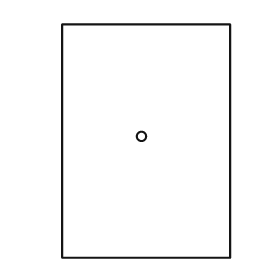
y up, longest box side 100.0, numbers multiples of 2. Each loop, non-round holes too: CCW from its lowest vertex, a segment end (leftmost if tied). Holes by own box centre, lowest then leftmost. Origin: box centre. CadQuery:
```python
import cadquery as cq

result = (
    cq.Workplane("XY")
    .moveTo(-36.0, -50.0)
    .lineTo(36.0, -50.0)
    .lineTo(36.0, 50.0)
    .lineTo(-36.0, 50.0)
    .close()
    .moveTo(-2.0, 2.0)
    .circle(2.0)
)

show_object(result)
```